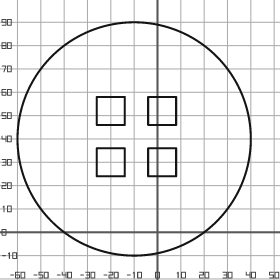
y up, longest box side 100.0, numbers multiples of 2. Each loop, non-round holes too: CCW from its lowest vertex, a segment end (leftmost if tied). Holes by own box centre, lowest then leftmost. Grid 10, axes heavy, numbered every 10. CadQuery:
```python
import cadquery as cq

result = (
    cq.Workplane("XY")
    .moveTo(-10.0, 40.0)
    .circle(50.0)
    .moveTo(-26.0, 24.0)
    .lineTo(-14.0, 24.0)
    .lineTo(-14.0, 36.0)
    .lineTo(-26.0, 36.0)
    .close()
    .moveTo(-4.0, 24.0)
    .lineTo(8.0, 24.0)
    .lineTo(8.0, 36.0)
    .lineTo(-4.0, 36.0)
    .close()
    .moveTo(-26.0, 46.0)
    .lineTo(-14.0, 46.0)
    .lineTo(-14.0, 58.0)
    .lineTo(-26.0, 58.0)
    .close()
    .moveTo(-4.0, 46.0)
    .lineTo(8.0, 46.0)
    .lineTo(8.0, 58.0)
    .lineTo(-4.0, 58.0)
    .close()
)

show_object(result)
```